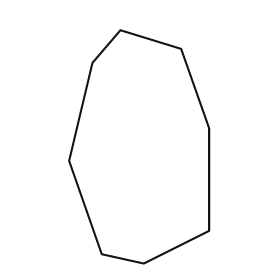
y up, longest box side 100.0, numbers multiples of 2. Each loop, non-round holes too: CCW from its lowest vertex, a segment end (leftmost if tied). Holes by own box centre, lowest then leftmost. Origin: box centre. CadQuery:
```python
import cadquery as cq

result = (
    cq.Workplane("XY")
    .moveTo(2.0, -50.0)
    .lineTo(30.0, -36.0)
    .lineTo(30.0, 8.0)
    .lineTo(18.0, 42.0)
    .lineTo(-8.0, 50.0)
    .lineTo(-20.0, 36.0)
    .lineTo(-30.0, -6.0)
    .lineTo(-16.0, -46.0)
    .close()
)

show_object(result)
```